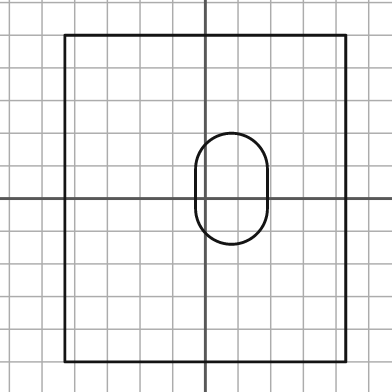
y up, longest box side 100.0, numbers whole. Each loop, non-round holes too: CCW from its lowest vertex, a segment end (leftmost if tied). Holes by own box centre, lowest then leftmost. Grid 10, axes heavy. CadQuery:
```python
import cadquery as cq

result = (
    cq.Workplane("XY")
    .moveTo(-43.0, -50.0)
    .lineTo(43.0, -50.0)
    .lineTo(43.0, 50.0)
    .lineTo(-43.0, 50.0)
    .close()
    .moveTo(-3.0, -3.0)
    .threePointArc((8.0, -14.0), (19.0, -3.0))
    .lineTo(19.0, 9.0)
    .threePointArc((8.0, 20.0), (-3.0, 9.0))
    .close()
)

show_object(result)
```